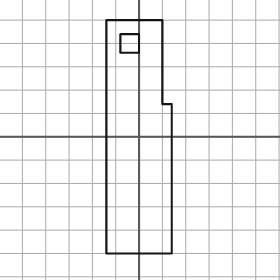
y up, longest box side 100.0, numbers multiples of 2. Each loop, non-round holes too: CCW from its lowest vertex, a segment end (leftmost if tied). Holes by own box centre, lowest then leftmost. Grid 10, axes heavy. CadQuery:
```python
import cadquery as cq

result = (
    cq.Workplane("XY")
    .moveTo(-14.0, -50.0)
    .lineTo(14.0, -50.0)
    .lineTo(14.0, 14.0)
    .lineTo(10.0, 14.0)
    .lineTo(10.0, 50.0)
    .lineTo(-14.0, 50.0)
    .close()
    .moveTo(-8.0, 36.0)
    .lineTo(0.0, 36.0)
    .lineTo(0.0, 44.0)
    .lineTo(-8.0, 44.0)
    .close()
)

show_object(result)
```